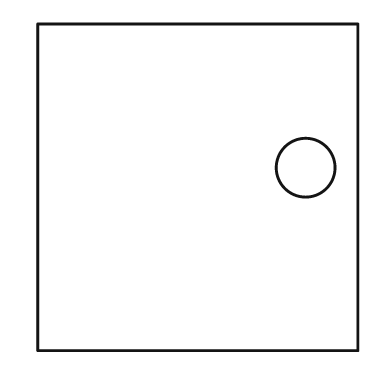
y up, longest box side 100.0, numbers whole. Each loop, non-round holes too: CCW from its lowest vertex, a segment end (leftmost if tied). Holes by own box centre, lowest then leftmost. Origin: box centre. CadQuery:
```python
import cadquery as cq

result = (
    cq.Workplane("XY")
    .moveTo(-49.0, -50.0)
    .lineTo(49.0, -50.0)
    .lineTo(49.0, 50.0)
    .lineTo(-49.0, 50.0)
    .close()
    .moveTo(33.0, 6.0)
    .circle(9.0)
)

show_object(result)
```